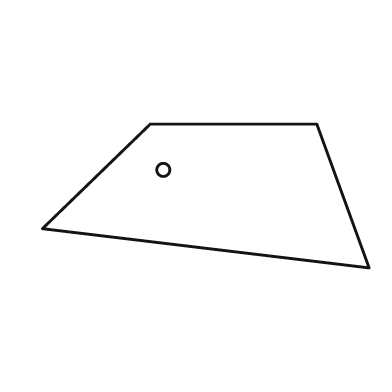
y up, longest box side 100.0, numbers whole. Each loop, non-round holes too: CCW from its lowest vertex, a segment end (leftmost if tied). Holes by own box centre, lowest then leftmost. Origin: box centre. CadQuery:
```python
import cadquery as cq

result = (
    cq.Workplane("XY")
    .moveTo(50.0, -22.0)
    .lineTo(34.0, 22.0)
    .lineTo(-17.0, 22.0)
    .lineTo(-50.0, -10.0)
    .close()
    .moveTo(-13.0, 8.0)
    .circle(2.0)
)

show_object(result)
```